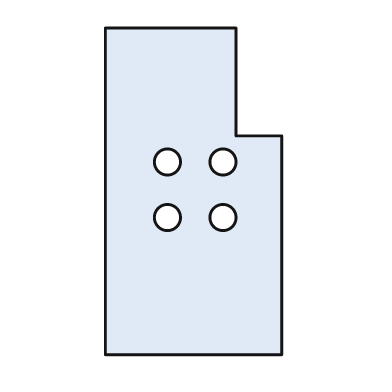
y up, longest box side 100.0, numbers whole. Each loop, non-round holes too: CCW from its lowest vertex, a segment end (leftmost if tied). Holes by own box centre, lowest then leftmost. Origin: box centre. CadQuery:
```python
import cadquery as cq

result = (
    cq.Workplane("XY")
    .moveTo(-27.0, -50.0)
    .lineTo(27.0, -50.0)
    .lineTo(27.0, 17.0)
    .lineTo(13.0, 17.0)
    .lineTo(13.0, 50.0)
    .lineTo(-27.0, 50.0)
    .close()
    .moveTo(-8.0, -8.0)
    .circle(4.0)
    .moveTo(9.0, -8.0)
    .circle(4.0)
    .moveTo(-8.0, 9.0)
    .circle(4.0)
    .moveTo(9.0, 9.0)
    .circle(4.0)
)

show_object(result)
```